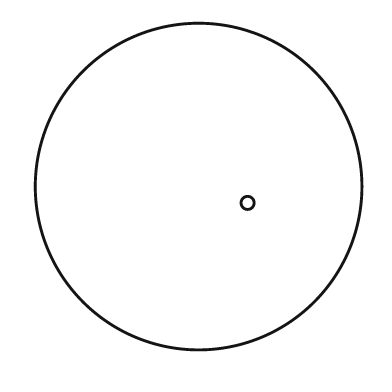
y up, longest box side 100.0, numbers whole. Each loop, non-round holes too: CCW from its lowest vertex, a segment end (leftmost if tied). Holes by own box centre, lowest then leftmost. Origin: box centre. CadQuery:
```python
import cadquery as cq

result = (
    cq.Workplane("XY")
    .moveTo(0.0, 0.0)
    .circle(50.0)
    .moveTo(15.0, -5.0)
    .circle(2.0)
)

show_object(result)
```